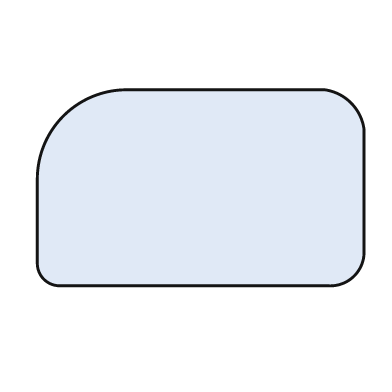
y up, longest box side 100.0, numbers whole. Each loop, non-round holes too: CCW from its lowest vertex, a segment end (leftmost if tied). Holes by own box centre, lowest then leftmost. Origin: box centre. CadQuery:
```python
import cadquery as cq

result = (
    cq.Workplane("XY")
    .moveTo(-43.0, -30.0)
    .lineTo(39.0, -30.0)
    .threePointArc((47.0, -27.0), (50.0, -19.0))
    .lineTo(50.0, 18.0)
    .threePointArc((46.0, 26.0), (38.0, 30.0))
    .lineTo(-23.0, 30.0)
    .threePointArc((-42.0, 22.0), (-50.0, 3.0))
    .lineTo(-50.0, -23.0)
    .threePointArc((-48.0, -28.0), (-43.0, -30.0))
    .close()
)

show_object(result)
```